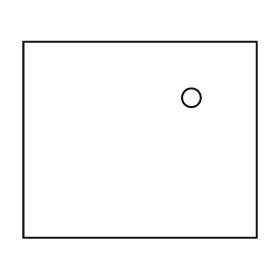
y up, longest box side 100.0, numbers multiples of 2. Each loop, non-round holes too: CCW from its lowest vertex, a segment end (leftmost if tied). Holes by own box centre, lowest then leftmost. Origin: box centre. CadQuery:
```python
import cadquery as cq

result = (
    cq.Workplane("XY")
    .moveTo(-50.0, -42.0)
    .lineTo(50.0, -42.0)
    .lineTo(50.0, 42.0)
    .lineTo(-50.0, 42.0)
    .close()
    .moveTo(22.0, 18.0)
    .circle(4.0)
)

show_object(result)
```